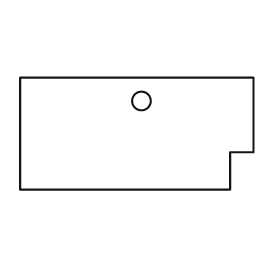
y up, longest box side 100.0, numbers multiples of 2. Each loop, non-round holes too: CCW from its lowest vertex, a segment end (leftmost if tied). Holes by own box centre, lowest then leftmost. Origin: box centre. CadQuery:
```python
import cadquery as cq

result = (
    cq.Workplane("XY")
    .moveTo(-50.0, -24.0)
    .lineTo(40.0, -24.0)
    .lineTo(40.0, -8.0)
    .lineTo(50.0, -8.0)
    .lineTo(50.0, 24.0)
    .lineTo(-50.0, 24.0)
    .close()
    .moveTo(2.0, 14.0)
    .circle(4.0)
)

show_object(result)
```